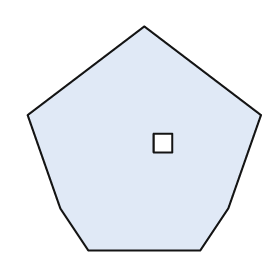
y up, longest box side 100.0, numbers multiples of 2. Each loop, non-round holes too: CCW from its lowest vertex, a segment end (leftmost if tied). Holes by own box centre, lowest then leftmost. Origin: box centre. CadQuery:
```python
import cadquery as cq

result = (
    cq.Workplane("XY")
    .moveTo(-24.0, -48.0)
    .lineTo(24.0, -48.0)
    .lineTo(36.0, -30.0)
    .lineTo(50.0, 10.0)
    .lineTo(0.0, 48.0)
    .lineTo(-50.0, 10.0)
    .lineTo(-36.0, -30.0)
    .close()
    .moveTo(4.0, -6.0)
    .lineTo(12.0, -6.0)
    .lineTo(12.0, 2.0)
    .lineTo(4.0, 2.0)
    .close()
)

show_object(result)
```